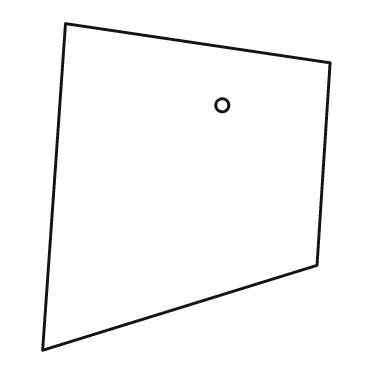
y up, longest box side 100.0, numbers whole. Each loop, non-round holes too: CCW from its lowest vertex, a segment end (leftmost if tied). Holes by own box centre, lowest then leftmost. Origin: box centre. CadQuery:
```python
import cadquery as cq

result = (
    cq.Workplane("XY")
    .moveTo(-44.0, -50.0)
    .lineTo(40.0, -24.0)
    .lineTo(44.0, 38.0)
    .lineTo(-37.0, 50.0)
    .close()
    .moveTo(11.0, 25.0)
    .circle(2.0)
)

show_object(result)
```